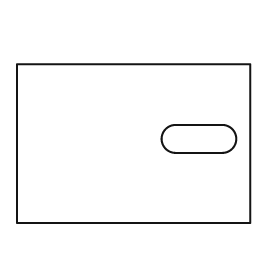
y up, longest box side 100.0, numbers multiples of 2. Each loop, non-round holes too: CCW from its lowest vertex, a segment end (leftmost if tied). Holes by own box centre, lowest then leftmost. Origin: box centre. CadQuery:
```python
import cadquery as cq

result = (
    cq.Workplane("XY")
    .moveTo(-50.0, -34.0)
    .lineTo(50.0, -34.0)
    .lineTo(50.0, 34.0)
    .lineTo(-50.0, 34.0)
    .close()
    .moveTo(18.0, -4.0)
    .lineTo(38.0, -4.0)
    .threePointArc((44.0, 2.0), (38.0, 8.0))
    .lineTo(18.0, 8.0)
    .threePointArc((12.0, 2.0), (18.0, -4.0))
    .close()
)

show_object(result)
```